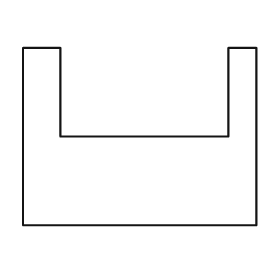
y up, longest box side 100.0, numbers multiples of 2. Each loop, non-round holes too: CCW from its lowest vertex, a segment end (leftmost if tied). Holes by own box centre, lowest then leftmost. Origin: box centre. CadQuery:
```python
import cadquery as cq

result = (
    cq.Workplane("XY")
    .moveTo(-50.0, -38.0)
    .lineTo(50.0, -38.0)
    .lineTo(50.0, 38.0)
    .lineTo(38.0, 38.0)
    .lineTo(38.0, 0.0)
    .lineTo(-34.0, 0.0)
    .lineTo(-34.0, 38.0)
    .lineTo(-50.0, 38.0)
    .close()
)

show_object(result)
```